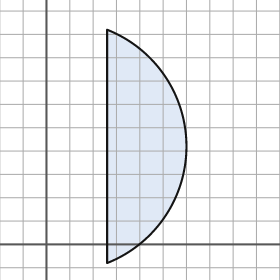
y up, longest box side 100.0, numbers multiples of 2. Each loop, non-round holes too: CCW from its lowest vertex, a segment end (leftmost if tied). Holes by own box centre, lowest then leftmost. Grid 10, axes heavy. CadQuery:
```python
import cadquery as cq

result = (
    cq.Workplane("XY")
    .moveTo(26.0, -8.0)
    .threePointArc((60.0, 42.0), (26.0, 92.0))
    .close()
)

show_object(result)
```